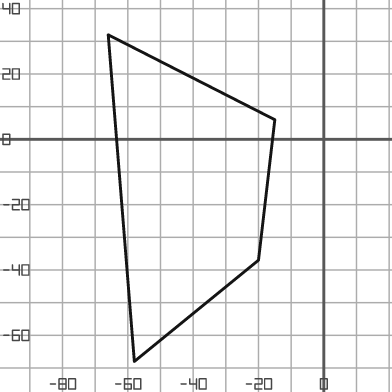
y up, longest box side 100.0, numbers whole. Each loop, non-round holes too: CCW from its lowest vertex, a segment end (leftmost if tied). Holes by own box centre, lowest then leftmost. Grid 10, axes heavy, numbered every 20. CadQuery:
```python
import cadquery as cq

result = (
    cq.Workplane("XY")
    .moveTo(-58.0, -68.0)
    .lineTo(-20.0, -37.0)
    .lineTo(-15.0, 6.0)
    .lineTo(-66.0, 32.0)
    .close()
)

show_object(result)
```